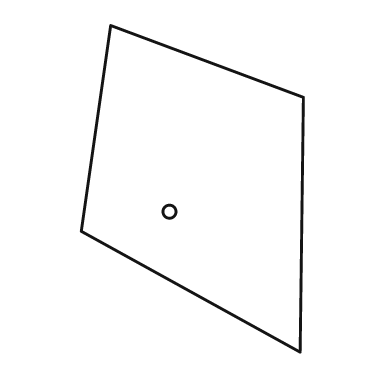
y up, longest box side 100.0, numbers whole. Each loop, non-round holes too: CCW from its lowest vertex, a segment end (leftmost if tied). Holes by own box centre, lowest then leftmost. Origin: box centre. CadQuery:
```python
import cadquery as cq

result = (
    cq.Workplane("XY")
    .moveTo(33.0, -50.0)
    .lineTo(34.0, 28.0)
    .lineTo(-25.0, 50.0)
    .lineTo(-34.0, -13.0)
    .close()
    .moveTo(-7.0, -7.0)
    .circle(2.0)
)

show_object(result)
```